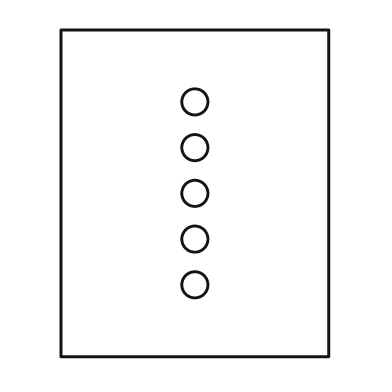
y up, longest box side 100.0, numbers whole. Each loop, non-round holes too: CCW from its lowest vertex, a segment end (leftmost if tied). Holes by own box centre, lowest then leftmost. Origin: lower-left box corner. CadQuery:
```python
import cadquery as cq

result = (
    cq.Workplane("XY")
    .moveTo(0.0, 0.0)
    .lineTo(82.0, 0.0)
    .lineTo(82.0, 100.0)
    .lineTo(0.0, 100.0)
    .close()
    .moveTo(41.0, 22.0)
    .circle(4.0)
    .moveTo(41.0, 36.0)
    .circle(4.0)
    .moveTo(41.0, 50.0)
    .circle(4.0)
    .moveTo(41.0, 64.0)
    .circle(4.0)
    .moveTo(41.0, 78.0)
    .circle(4.0)
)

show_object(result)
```